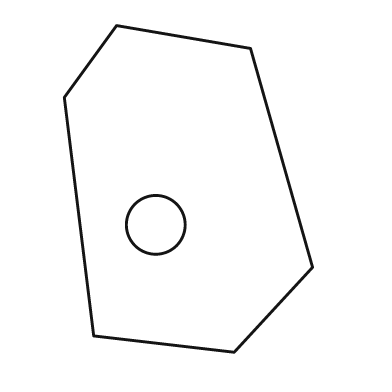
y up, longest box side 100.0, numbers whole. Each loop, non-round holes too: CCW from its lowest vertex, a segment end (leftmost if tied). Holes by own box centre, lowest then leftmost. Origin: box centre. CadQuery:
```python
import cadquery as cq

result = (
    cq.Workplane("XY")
    .moveTo(14.0, -50.0)
    .lineTo(38.0, -24.0)
    .lineTo(19.0, 43.0)
    .lineTo(-22.0, 50.0)
    .lineTo(-38.0, 28.0)
    .lineTo(-29.0, -45.0)
    .close()
    .moveTo(-10.0, -11.0)
    .circle(9.0)
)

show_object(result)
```